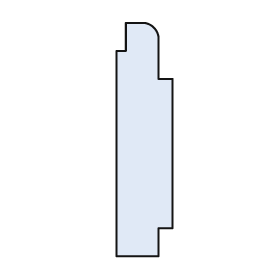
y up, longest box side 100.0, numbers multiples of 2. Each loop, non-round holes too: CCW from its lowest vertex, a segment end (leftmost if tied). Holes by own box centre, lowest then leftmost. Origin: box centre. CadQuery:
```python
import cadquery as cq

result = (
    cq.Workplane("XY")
    .moveTo(-12.0, -50.0)
    .lineTo(6.0, -50.0)
    .lineTo(6.0, -38.0)
    .lineTo(12.0, -38.0)
    .lineTo(12.0, 26.0)
    .lineTo(6.0, 26.0)
    .lineTo(6.0, 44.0)
    .threePointArc((4.0, 48.0), (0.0, 50.0))
    .lineTo(-8.0, 50.0)
    .lineTo(-8.0, 38.0)
    .lineTo(-12.0, 38.0)
    .close()
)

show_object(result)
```